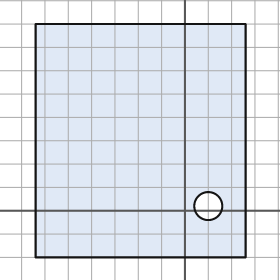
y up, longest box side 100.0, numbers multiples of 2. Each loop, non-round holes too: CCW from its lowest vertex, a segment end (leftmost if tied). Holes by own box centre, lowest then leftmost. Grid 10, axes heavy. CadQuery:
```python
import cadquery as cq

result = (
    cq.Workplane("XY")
    .moveTo(-64.0, -20.0)
    .lineTo(26.0, -20.0)
    .lineTo(26.0, 80.0)
    .lineTo(-64.0, 80.0)
    .close()
    .moveTo(10.0, 2.0)
    .circle(6.0)
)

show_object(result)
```